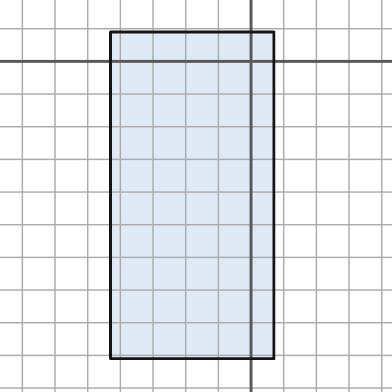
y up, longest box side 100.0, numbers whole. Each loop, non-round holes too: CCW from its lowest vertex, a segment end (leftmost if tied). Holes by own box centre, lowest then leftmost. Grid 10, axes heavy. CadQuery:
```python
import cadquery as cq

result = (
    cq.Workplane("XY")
    .moveTo(-43.0, -91.0)
    .lineTo(7.0, -91.0)
    .lineTo(7.0, 9.0)
    .lineTo(-43.0, 9.0)
    .close()
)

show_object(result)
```